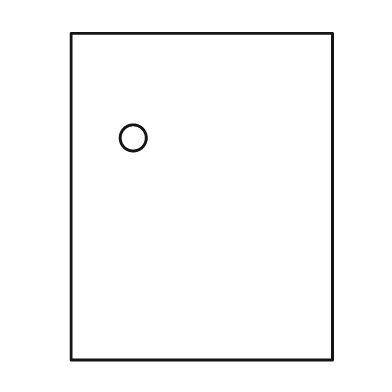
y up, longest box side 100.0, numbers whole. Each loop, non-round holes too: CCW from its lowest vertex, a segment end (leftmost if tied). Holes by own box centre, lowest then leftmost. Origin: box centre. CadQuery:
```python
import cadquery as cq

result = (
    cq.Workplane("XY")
    .moveTo(-40.0, -50.0)
    .lineTo(40.0, -50.0)
    .lineTo(40.0, 50.0)
    .lineTo(-40.0, 50.0)
    .close()
    .moveTo(-21.0, 18.0)
    .circle(4.0)
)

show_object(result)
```